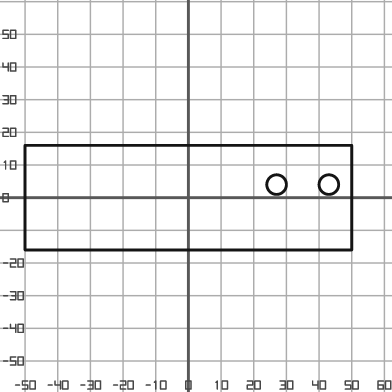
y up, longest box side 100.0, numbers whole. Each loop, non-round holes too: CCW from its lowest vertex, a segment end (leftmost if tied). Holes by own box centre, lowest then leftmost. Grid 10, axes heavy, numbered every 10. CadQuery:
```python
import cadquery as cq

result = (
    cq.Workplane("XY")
    .moveTo(-50.0, -16.0)
    .lineTo(50.0, -16.0)
    .lineTo(50.0, 16.0)
    .lineTo(-50.0, 16.0)
    .close()
    .moveTo(27.0, 4.0)
    .circle(3.0)
    .moveTo(43.0, 4.0)
    .circle(3.0)
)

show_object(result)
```